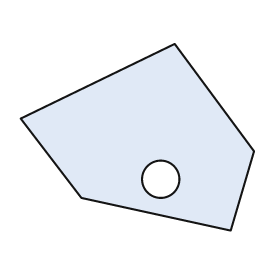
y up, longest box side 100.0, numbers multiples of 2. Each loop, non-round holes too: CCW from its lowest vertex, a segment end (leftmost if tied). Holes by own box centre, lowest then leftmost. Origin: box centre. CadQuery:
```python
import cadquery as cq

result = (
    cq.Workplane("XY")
    .moveTo(40.0, -40.0)
    .lineTo(50.0, -6.0)
    .lineTo(16.0, 40.0)
    .lineTo(-50.0, 8.0)
    .lineTo(-24.0, -26.0)
    .close()
    .moveTo(10.0, -18.0)
    .circle(8.0)
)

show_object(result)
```